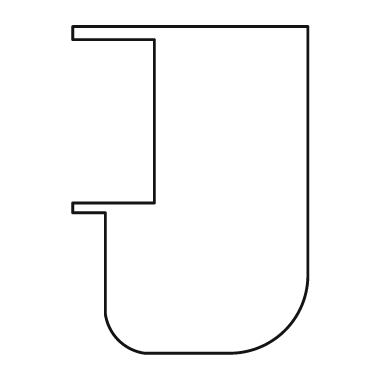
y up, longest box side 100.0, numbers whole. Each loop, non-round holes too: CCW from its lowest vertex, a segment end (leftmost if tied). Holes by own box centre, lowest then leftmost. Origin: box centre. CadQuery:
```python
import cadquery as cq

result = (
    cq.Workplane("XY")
    .moveTo(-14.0, -50.0)
    .lineTo(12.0, -50.0)
    .threePointArc((29.0, -43.0), (36.0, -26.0))
    .lineTo(36.0, 50.0)
    .lineTo(-36.0, 50.0)
    .lineTo(-36.0, 46.0)
    .lineTo(-11.0, 46.0)
    .lineTo(-11.0, -4.0)
    .lineTo(-36.0, -4.0)
    .lineTo(-36.0, -7.0)
    .lineTo(-26.0, -7.0)
    .lineTo(-26.0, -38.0)
    .threePointArc((-22.0, -46.0), (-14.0, -50.0))
    .close()
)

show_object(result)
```